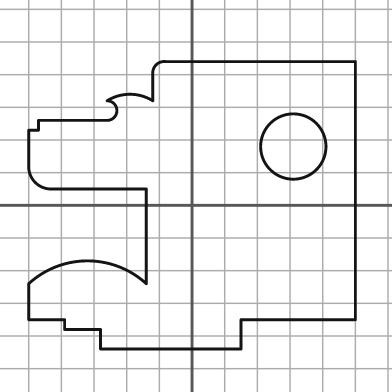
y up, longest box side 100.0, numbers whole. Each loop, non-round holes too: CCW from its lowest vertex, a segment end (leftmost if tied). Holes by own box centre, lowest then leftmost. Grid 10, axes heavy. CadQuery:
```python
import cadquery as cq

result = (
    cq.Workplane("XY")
    .moveTo(-28.0, -44.0)
    .lineTo(15.0, -44.0)
    .lineTo(15.0, -35.0)
    .lineTo(50.0, -35.0)
    .lineTo(50.0, 44.0)
    .lineTo(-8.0, 44.0)
    .threePointArc((-11.0, 43.0), (-12.0, 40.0))
    .lineTo(-12.0, 32.0)
    .threePointArc((-19.0, 34.0), (-26.0, 32.0))
    .threePointArc((-23.0, 29.0), (-26.0, 26.0))
    .lineTo(-47.0, 26.0)
    .lineTo(-47.0, 23.0)
    .lineTo(-50.0, 23.0)
    .lineTo(-50.0, 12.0)
    .threePointArc((-48.0, 7.0), (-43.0, 5.0))
    .lineTo(-14.0, 5.0)
    .lineTo(-14.0, -24.0)
    .threePointArc((-32.0, -17.0), (-50.0, -24.0))
    .lineTo(-50.0, -35.0)
    .lineTo(-39.0, -35.0)
    .lineTo(-39.0, -38.0)
    .lineTo(-28.0, -38.0)
    .close()
    .moveTo(31.0, 18.0)
    .circle(10.0)
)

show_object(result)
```